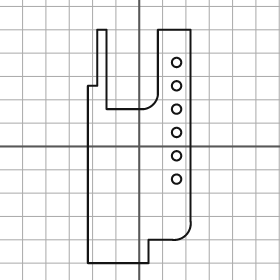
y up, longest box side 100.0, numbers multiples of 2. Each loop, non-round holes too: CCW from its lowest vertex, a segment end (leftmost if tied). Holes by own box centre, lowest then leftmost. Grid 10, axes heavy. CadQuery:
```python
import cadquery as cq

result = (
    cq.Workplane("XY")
    .moveTo(-22.0, -50.0)
    .lineTo(4.0, -50.0)
    .lineTo(4.0, -40.0)
    .lineTo(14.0, -40.0)
    .threePointArc((20.0, -38.0), (22.0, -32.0))
    .lineTo(22.0, 50.0)
    .lineTo(8.0, 50.0)
    .lineTo(8.0, 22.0)
    .threePointArc((6.0, 18.0), (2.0, 16.0))
    .lineTo(-14.0, 16.0)
    .lineTo(-14.0, 50.0)
    .lineTo(-18.0, 50.0)
    .lineTo(-18.0, 26.0)
    .lineTo(-22.0, 26.0)
    .close()
    .moveTo(16.0, -14.0)
    .circle(2.0)
    .moveTo(16.0, -4.0)
    .circle(2.0)
    .moveTo(16.0, 6.0)
    .circle(2.0)
    .moveTo(16.0, 16.0)
    .circle(2.0)
    .moveTo(16.0, 26.0)
    .circle(2.0)
    .moveTo(16.0, 36.0)
    .circle(2.0)
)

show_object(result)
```